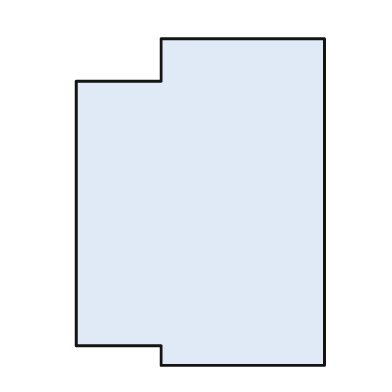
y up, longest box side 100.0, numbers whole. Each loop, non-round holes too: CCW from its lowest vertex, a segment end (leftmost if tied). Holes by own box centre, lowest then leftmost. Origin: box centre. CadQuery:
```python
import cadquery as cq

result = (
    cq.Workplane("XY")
    .moveTo(-12.0, -50.0)
    .lineTo(38.0, -50.0)
    .lineTo(38.0, 50.0)
    .lineTo(-12.0, 50.0)
    .lineTo(-12.0, 37.0)
    .lineTo(-38.0, 37.0)
    .lineTo(-38.0, -44.0)
    .lineTo(-12.0, -44.0)
    .close()
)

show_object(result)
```